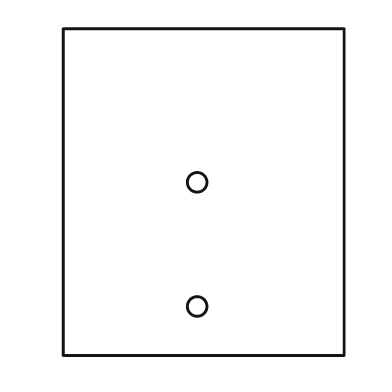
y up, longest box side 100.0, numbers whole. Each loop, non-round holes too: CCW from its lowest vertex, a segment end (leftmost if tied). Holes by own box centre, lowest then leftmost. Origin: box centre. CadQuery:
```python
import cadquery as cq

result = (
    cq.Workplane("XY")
    .moveTo(-43.0, -50.0)
    .lineTo(43.0, -50.0)
    .lineTo(43.0, 50.0)
    .lineTo(-43.0, 50.0)
    .close()
    .moveTo(-2.0, -35.0)
    .circle(3.0)
    .moveTo(-2.0, 3.0)
    .circle(3.0)
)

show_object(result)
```